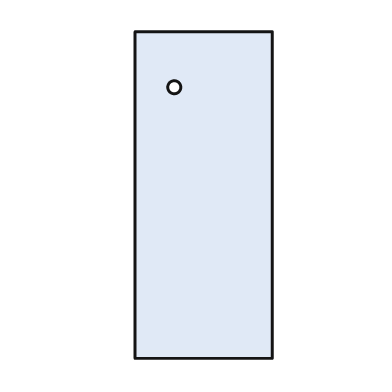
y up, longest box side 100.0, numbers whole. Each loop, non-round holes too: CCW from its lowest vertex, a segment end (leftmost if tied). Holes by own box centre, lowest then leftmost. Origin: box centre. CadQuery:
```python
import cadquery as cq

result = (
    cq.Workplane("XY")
    .moveTo(-21.0, -50.0)
    .lineTo(21.0, -50.0)
    .lineTo(21.0, 50.0)
    .lineTo(-21.0, 50.0)
    .close()
    .moveTo(-9.0, 33.0)
    .circle(2.0)
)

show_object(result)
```